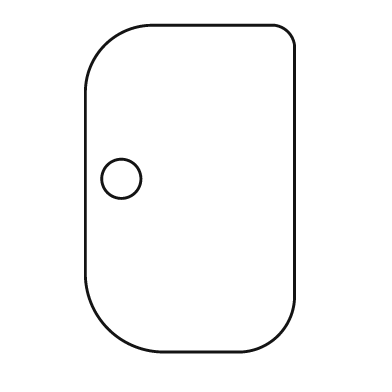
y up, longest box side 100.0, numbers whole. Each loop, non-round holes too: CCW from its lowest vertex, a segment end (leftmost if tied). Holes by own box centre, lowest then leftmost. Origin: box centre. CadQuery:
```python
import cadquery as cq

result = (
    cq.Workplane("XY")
    .moveTo(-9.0, -50.0)
    .lineTo(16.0, -50.0)
    .threePointArc((27.0, -45.0), (32.0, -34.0))
    .lineTo(32.0, 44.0)
    .threePointArc((30.0, 48.0), (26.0, 50.0))
    .lineTo(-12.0, 50.0)
    .threePointArc((-26.0, 44.0), (-32.0, 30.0))
    .lineTo(-32.0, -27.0)
    .threePointArc((-25.0, -43.0), (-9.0, -50.0))
    .close()
    .moveTo(-21.0, 3.0)
    .circle(6.0)
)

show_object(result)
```